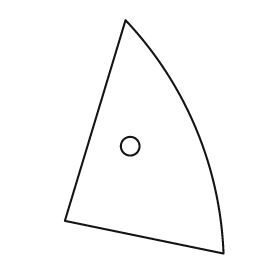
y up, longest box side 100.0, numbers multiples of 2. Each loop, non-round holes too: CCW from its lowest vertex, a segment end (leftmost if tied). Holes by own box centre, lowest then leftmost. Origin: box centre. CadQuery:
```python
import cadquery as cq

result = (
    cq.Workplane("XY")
    .moveTo(34.0, -50.0)
    .threePointArc((22.0, 4.0), (-8.0, 50.0))
    .lineTo(-34.0, -36.0)
    .close()
    .moveTo(-6.0, -4.0)
    .circle(4.0)
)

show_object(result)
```